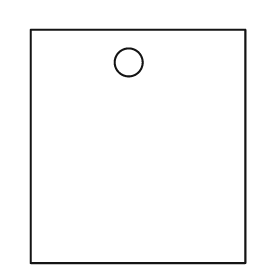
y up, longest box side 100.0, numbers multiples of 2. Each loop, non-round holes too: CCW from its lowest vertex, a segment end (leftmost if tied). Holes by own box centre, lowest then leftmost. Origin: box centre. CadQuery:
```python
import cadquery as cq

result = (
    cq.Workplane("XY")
    .moveTo(-46.0, -50.0)
    .lineTo(46.0, -50.0)
    .lineTo(46.0, 50.0)
    .lineTo(-46.0, 50.0)
    .close()
    .moveTo(-4.0, 36.0)
    .circle(6.0)
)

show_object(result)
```